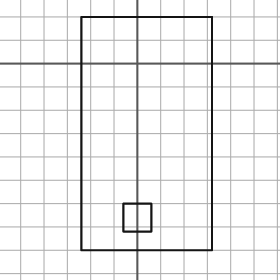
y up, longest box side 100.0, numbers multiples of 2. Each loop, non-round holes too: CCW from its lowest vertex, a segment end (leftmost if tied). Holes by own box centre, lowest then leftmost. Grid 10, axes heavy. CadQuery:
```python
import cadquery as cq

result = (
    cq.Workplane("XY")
    .moveTo(-24.0, -80.0)
    .lineTo(32.0, -80.0)
    .lineTo(32.0, 20.0)
    .lineTo(-24.0, 20.0)
    .close()
    .moveTo(-6.0, -72.0)
    .lineTo(6.0, -72.0)
    .lineTo(6.0, -60.0)
    .lineTo(-6.0, -60.0)
    .close()
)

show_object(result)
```